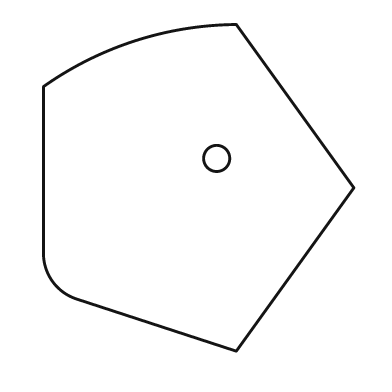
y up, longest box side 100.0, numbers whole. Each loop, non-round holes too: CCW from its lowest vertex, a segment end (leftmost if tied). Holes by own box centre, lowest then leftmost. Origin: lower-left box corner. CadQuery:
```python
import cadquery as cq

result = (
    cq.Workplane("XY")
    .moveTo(59.0, 0.0)
    .lineTo(95.0, 50.0)
    .lineTo(59.0, 100.0)
    .threePointArc((28.0, 95.0), (0.0, 81.0))
    .lineTo(0.0, 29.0)
    .threePointArc((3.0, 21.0), (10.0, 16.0))
    .close()
    .moveTo(53.0, 59.0)
    .circle(4.0)
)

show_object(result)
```